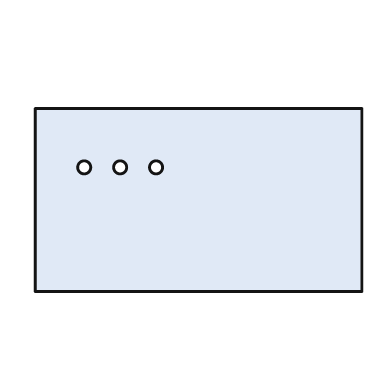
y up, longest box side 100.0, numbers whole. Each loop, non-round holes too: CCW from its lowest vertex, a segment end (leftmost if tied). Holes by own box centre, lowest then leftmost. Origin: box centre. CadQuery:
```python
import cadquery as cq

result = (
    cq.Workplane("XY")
    .moveTo(-50.0, -28.0)
    .lineTo(50.0, -28.0)
    .lineTo(50.0, 28.0)
    .lineTo(-50.0, 28.0)
    .close()
    .moveTo(-35.0, 10.0)
    .circle(2.0)
    .moveTo(-24.0, 10.0)
    .circle(2.0)
    .moveTo(-13.0, 10.0)
    .circle(2.0)
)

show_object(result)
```